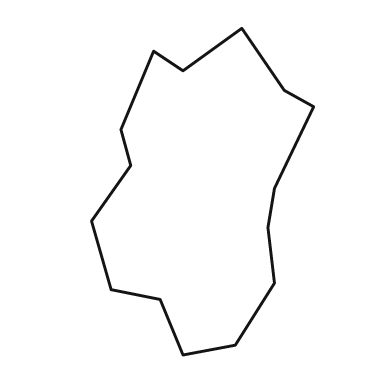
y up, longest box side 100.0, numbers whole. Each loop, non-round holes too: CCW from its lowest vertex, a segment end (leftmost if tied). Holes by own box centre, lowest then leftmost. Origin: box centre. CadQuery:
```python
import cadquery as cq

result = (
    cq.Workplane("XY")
    .moveTo(-6.0, -50.0)
    .lineTo(10.0, -47.0)
    .lineTo(22.0, -28.0)
    .lineTo(20.0, -11.0)
    .lineTo(22.0, 1.0)
    .lineTo(34.0, 26.0)
    .lineTo(25.0, 31.0)
    .lineTo(12.0, 50.0)
    .lineTo(-6.0, 37.0)
    .lineTo(-15.0, 43.0)
    .lineTo(-25.0, 19.0)
    .lineTo(-22.0, 8.0)
    .lineTo(-34.0, -9.0)
    .lineTo(-28.0, -30.0)
    .lineTo(-13.0, -33.0)
    .close()
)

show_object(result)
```